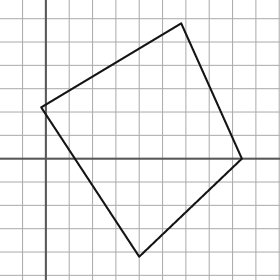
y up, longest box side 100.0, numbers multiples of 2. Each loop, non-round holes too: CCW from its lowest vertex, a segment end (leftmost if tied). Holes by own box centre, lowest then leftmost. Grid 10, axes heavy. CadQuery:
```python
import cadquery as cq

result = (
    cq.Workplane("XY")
    .moveTo(40.0, -42.0)
    .lineTo(84.0, 0.0)
    .lineTo(58.0, 58.0)
    .lineTo(-2.0, 22.0)
    .close()
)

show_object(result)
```